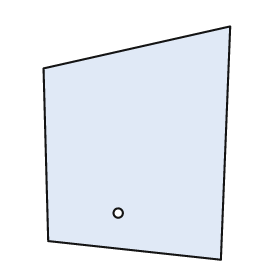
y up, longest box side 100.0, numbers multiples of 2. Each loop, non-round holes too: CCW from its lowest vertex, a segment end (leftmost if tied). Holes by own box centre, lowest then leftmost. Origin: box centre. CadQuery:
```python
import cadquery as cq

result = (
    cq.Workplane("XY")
    .moveTo(36.0, -50.0)
    .lineTo(40.0, 50.0)
    .lineTo(-40.0, 32.0)
    .lineTo(-38.0, -42.0)
    .close()
    .moveTo(-8.0, -30.0)
    .circle(2.0)
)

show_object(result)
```